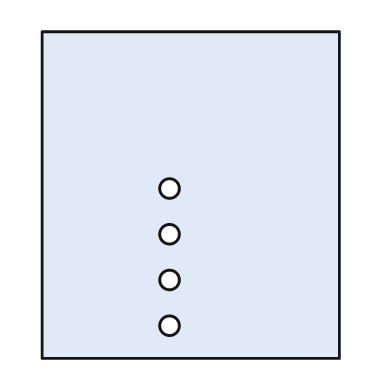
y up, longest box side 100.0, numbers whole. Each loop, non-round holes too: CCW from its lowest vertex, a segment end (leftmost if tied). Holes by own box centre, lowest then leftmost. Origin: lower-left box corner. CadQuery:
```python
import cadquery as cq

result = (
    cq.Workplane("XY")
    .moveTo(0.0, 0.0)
    .lineTo(91.0, 0.0)
    .lineTo(91.0, 100.0)
    .lineTo(0.0, 100.0)
    .close()
    .moveTo(39.0, 10.0)
    .circle(3.0)
    .moveTo(39.0, 24.0)
    .circle(3.0)
    .moveTo(39.0, 38.0)
    .circle(3.0)
    .moveTo(39.0, 52.0)
    .circle(3.0)
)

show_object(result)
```